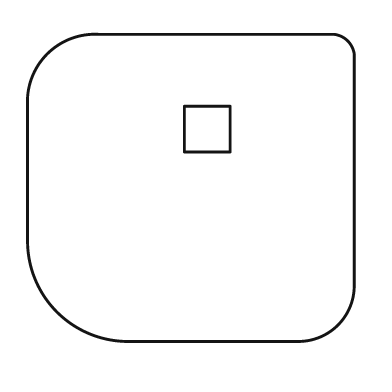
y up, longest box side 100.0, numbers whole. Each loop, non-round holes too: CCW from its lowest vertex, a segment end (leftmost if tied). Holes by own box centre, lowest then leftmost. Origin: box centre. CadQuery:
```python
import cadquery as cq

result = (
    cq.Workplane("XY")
    .moveTo(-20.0, -47.0)
    .lineTo(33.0, -47.0)
    .threePointArc((45.0, -42.0), (50.0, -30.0))
    .lineTo(50.0, 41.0)
    .threePointArc((48.0, 45.0), (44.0, 47.0))
    .lineTo(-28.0, 47.0)
    .threePointArc((-44.0, 41.0), (-50.0, 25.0))
    .lineTo(-50.0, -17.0)
    .threePointArc((-41.0, -38.0), (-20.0, -47.0))
    .close()
    .moveTo(-2.0, 11.0)
    .lineTo(12.0, 11.0)
    .lineTo(12.0, 25.0)
    .lineTo(-2.0, 25.0)
    .close()
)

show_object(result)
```